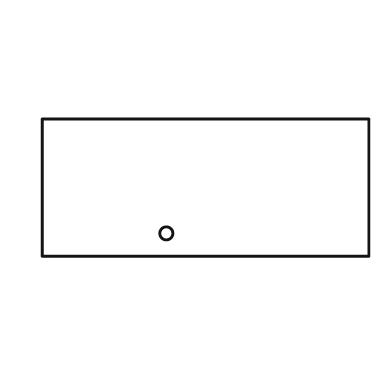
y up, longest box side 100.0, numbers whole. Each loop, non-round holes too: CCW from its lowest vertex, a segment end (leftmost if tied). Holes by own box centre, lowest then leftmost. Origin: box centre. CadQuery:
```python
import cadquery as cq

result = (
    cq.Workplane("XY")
    .moveTo(-50.0, -21.0)
    .lineTo(50.0, -21.0)
    .lineTo(50.0, 21.0)
    .lineTo(-50.0, 21.0)
    .close()
    .moveTo(-12.0, -14.0)
    .circle(2.0)
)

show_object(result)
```